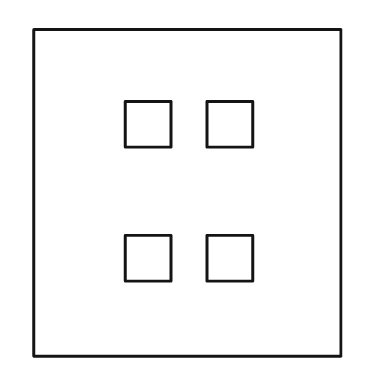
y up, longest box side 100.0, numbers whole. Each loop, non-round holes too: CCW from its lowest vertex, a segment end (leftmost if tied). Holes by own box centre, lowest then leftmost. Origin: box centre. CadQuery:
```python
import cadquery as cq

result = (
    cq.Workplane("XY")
    .moveTo(-47.0, -50.0)
    .lineTo(47.0, -50.0)
    .lineTo(47.0, 50.0)
    .lineTo(-47.0, 50.0)
    .close()
    .moveTo(-19.0, -27.0)
    .lineTo(-5.0, -27.0)
    .lineTo(-5.0, -13.0)
    .lineTo(-19.0, -13.0)
    .close()
    .moveTo(6.0, -27.0)
    .lineTo(20.0, -27.0)
    .lineTo(20.0, -13.0)
    .lineTo(6.0, -13.0)
    .close()
    .moveTo(-19.0, 14.0)
    .lineTo(-5.0, 14.0)
    .lineTo(-5.0, 28.0)
    .lineTo(-19.0, 28.0)
    .close()
    .moveTo(6.0, 14.0)
    .lineTo(20.0, 14.0)
    .lineTo(20.0, 28.0)
    .lineTo(6.0, 28.0)
    .close()
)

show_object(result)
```